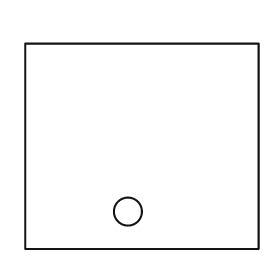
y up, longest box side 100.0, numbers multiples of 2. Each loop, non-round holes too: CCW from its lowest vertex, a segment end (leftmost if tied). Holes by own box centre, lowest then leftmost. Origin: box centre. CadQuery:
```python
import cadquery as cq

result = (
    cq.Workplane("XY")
    .moveTo(-50.0, -44.0)
    .lineTo(50.0, -44.0)
    .lineTo(50.0, 44.0)
    .lineTo(-50.0, 44.0)
    .close()
    .moveTo(-6.0, -28.0)
    .circle(6.0)
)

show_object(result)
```